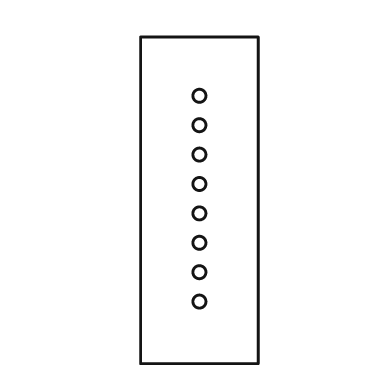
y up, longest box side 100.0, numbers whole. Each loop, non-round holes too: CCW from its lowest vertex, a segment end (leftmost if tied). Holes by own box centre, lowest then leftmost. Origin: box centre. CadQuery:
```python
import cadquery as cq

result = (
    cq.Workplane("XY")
    .moveTo(-18.0, -50.0)
    .lineTo(18.0, -50.0)
    .lineTo(18.0, 50.0)
    .lineTo(-18.0, 50.0)
    .close()
    .moveTo(0.0, -31.0)
    .circle(2.0)
    .moveTo(0.0, -22.0)
    .circle(2.0)
    .moveTo(0.0, -13.0)
    .circle(2.0)
    .moveTo(0.0, -4.0)
    .circle(2.0)
    .moveTo(0.0, 5.0)
    .circle(2.0)
    .moveTo(0.0, 14.0)
    .circle(2.0)
    .moveTo(0.0, 23.0)
    .circle(2.0)
    .moveTo(0.0, 32.0)
    .circle(2.0)
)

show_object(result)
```